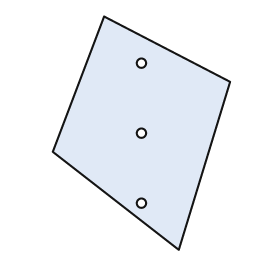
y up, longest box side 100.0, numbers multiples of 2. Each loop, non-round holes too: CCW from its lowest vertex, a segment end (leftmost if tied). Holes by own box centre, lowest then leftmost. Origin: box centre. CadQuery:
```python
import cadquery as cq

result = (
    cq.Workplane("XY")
    .moveTo(16.0, -50.0)
    .lineTo(38.0, 22.0)
    .lineTo(-16.0, 50.0)
    .lineTo(-38.0, -8.0)
    .close()
    .moveTo(0.0, -30.0)
    .circle(2.0)
    .moveTo(0.0, 0.0)
    .circle(2.0)
    .moveTo(0.0, 30.0)
    .circle(2.0)
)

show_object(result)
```